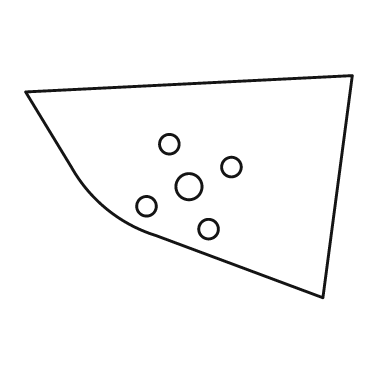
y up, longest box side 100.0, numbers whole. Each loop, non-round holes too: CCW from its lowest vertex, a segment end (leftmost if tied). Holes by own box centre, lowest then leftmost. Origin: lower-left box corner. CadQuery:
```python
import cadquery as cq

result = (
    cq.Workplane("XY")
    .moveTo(91.0, 0.0)
    .lineTo(100.0, 68.0)
    .lineTo(0.0, 63.0)
    .lineTo(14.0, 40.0)
    .threePointArc((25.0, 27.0), (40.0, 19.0))
    .close()
    .moveTo(56.0, 21.0)
    .circle(3.0)
    .moveTo(37.0, 28.0)
    .circle(3.0)
    .moveTo(50.0, 34.0)
    .circle(4.0)
    .moveTo(63.0, 40.0)
    .circle(3.0)
    .moveTo(44.0, 47.0)
    .circle(3.0)
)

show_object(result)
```